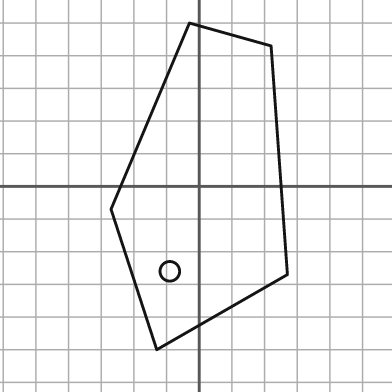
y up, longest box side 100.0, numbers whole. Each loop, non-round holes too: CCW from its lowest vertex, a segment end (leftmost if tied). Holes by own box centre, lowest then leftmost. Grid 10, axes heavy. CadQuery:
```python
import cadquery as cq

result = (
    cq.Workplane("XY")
    .moveTo(-13.0, -50.0)
    .lineTo(27.0, -27.0)
    .lineTo(22.0, 43.0)
    .lineTo(-3.0, 50.0)
    .lineTo(-27.0, -7.0)
    .close()
    .moveTo(-9.0, -26.0)
    .circle(3.0)
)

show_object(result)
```